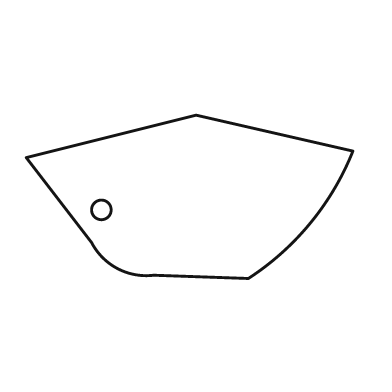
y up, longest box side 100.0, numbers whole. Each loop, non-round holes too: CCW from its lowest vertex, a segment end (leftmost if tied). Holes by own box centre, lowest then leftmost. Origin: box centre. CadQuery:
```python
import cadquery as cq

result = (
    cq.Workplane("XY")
    .moveTo(18.0, -25.0)
    .threePointArc((37.0, -8.0), (50.0, 14.0))
    .lineTo(2.0, 25.0)
    .lineTo(-50.0, 12.0)
    .lineTo(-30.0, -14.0)
    .threePointArc((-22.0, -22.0), (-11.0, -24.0))
    .close()
    .moveTo(-27.0, -4.0)
    .circle(3.0)
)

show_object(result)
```